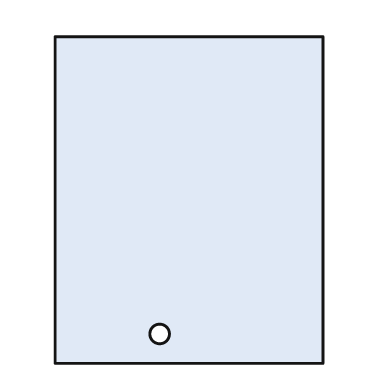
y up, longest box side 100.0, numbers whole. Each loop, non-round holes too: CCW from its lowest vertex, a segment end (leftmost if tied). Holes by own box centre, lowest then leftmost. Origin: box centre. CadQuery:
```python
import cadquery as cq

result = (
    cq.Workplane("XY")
    .moveTo(-41.0, -50.0)
    .lineTo(41.0, -50.0)
    .lineTo(41.0, 50.0)
    .lineTo(-41.0, 50.0)
    .close()
    .moveTo(-9.0, -41.0)
    .circle(3.0)
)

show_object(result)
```